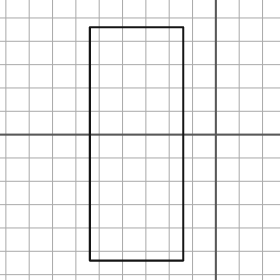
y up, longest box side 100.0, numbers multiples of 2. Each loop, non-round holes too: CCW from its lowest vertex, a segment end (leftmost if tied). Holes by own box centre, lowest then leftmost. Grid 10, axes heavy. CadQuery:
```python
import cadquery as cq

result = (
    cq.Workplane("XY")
    .moveTo(-54.0, -54.0)
    .lineTo(-14.0, -54.0)
    .lineTo(-14.0, 46.0)
    .lineTo(-54.0, 46.0)
    .close()
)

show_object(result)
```